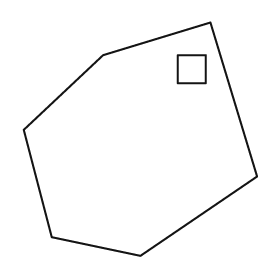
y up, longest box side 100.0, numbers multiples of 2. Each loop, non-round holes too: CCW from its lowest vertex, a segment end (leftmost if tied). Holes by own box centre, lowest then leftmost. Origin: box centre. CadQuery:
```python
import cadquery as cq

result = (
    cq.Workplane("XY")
    .moveTo(0.0, -50.0)
    .lineTo(50.0, -16.0)
    .lineTo(30.0, 50.0)
    .lineTo(-16.0, 36.0)
    .lineTo(-50.0, 4.0)
    .lineTo(-38.0, -42.0)
    .close()
    .moveTo(16.0, 24.0)
    .lineTo(28.0, 24.0)
    .lineTo(28.0, 36.0)
    .lineTo(16.0, 36.0)
    .close()
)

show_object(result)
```